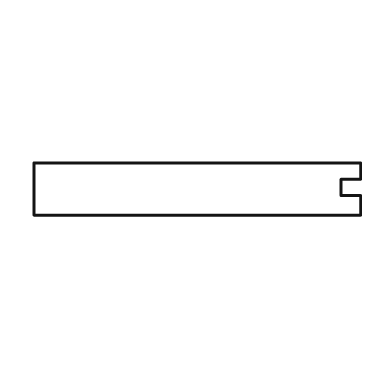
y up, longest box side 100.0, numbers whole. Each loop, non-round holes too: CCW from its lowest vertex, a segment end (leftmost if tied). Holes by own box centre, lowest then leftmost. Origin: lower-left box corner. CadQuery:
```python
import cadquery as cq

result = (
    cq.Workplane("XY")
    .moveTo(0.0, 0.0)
    .lineTo(100.0, 0.0)
    .lineTo(100.0, 6.0)
    .lineTo(94.0, 6.0)
    .lineTo(94.0, 11.0)
    .lineTo(100.0, 11.0)
    .lineTo(100.0, 16.0)
    .lineTo(0.0, 16.0)
    .close()
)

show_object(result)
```